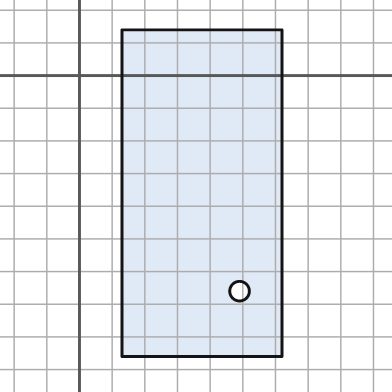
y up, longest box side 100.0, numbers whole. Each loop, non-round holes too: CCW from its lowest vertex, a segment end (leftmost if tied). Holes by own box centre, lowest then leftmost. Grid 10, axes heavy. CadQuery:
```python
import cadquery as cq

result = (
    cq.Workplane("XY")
    .moveTo(13.0, -86.0)
    .lineTo(62.0, -86.0)
    .lineTo(62.0, 14.0)
    .lineTo(13.0, 14.0)
    .close()
    .moveTo(49.0, -66.0)
    .circle(3.0)
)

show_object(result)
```